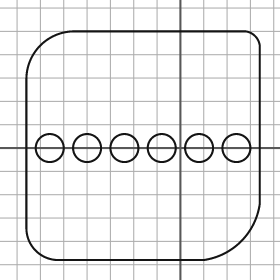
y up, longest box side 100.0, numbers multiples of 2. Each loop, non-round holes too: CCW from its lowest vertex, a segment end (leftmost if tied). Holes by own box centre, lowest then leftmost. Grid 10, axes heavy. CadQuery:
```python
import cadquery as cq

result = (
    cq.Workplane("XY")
    .moveTo(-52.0, -48.0)
    .lineTo(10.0, -48.0)
    .threePointArc((26.0, -40.0), (34.0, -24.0))
    .lineTo(34.0, 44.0)
    .threePointArc((32.0, 48.0), (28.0, 50.0))
    .lineTo(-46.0, 50.0)
    .threePointArc((-60.0, 44.0), (-66.0, 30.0))
    .lineTo(-66.0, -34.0)
    .threePointArc((-62.0, -44.0), (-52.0, -48.0))
    .close()
    .moveTo(-56.0, 0.0)
    .circle(6.0)
    .moveTo(-40.0, 0.0)
    .circle(6.0)
    .moveTo(-24.0, 0.0)
    .circle(6.0)
    .moveTo(-8.0, 0.0)
    .circle(6.0)
    .moveTo(8.0, 0.0)
    .circle(6.0)
    .moveTo(24.0, 0.0)
    .circle(6.0)
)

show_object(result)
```